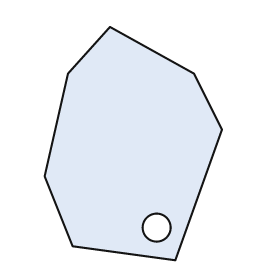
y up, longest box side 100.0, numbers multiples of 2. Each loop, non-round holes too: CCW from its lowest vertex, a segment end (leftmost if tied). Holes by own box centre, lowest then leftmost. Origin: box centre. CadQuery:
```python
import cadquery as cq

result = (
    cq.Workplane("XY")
    .moveTo(18.0, -50.0)
    .lineTo(38.0, 6.0)
    .lineTo(26.0, 30.0)
    .lineTo(-10.0, 50.0)
    .lineTo(-28.0, 30.0)
    .lineTo(-38.0, -14.0)
    .lineTo(-26.0, -44.0)
    .close()
    .moveTo(10.0, -36.0)
    .circle(6.0)
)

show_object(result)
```